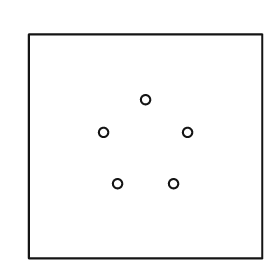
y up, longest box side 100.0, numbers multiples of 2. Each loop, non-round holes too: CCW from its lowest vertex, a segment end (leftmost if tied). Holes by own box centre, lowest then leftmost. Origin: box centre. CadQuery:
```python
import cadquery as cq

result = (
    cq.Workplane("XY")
    .moveTo(-50.0, -48.0)
    .lineTo(50.0, -48.0)
    .lineTo(50.0, 48.0)
    .lineTo(-50.0, 48.0)
    .close()
    .moveTo(-12.0, -16.0)
    .circle(2.0)
    .moveTo(12.0, -16.0)
    .circle(2.0)
    .moveTo(-18.0, 6.0)
    .circle(2.0)
    .moveTo(18.0, 6.0)
    .circle(2.0)
    .moveTo(0.0, 20.0)
    .circle(2.0)
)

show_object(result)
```